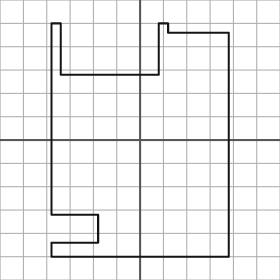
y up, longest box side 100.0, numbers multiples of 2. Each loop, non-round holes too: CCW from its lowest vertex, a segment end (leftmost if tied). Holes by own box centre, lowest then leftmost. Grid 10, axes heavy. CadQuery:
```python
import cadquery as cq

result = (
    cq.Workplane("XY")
    .moveTo(-38.0, -50.0)
    .lineTo(38.0, -50.0)
    .lineTo(38.0, 46.0)
    .lineTo(12.0, 46.0)
    .lineTo(12.0, 50.0)
    .lineTo(8.0, 50.0)
    .lineTo(8.0, 28.0)
    .lineTo(-34.0, 28.0)
    .lineTo(-34.0, 50.0)
    .lineTo(-38.0, 50.0)
    .lineTo(-38.0, -32.0)
    .lineTo(-18.0, -32.0)
    .lineTo(-18.0, -44.0)
    .lineTo(-38.0, -44.0)
    .close()
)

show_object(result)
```